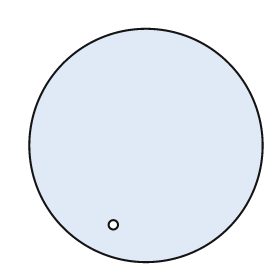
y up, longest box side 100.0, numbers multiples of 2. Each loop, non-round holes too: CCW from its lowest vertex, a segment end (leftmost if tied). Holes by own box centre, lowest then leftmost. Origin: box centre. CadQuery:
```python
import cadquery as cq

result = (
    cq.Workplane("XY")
    .moveTo(0.0, 0.0)
    .circle(50.0)
    .moveTo(-14.0, -34.0)
    .circle(2.0)
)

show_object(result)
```